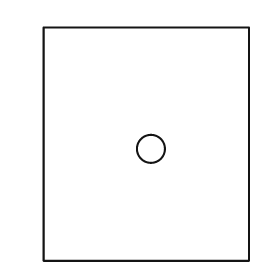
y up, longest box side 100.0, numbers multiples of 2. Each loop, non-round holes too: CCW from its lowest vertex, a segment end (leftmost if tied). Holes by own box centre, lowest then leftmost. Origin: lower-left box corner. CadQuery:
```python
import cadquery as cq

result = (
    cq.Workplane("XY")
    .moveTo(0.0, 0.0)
    .lineTo(88.0, 0.0)
    .lineTo(88.0, 100.0)
    .lineTo(0.0, 100.0)
    .close()
    .moveTo(46.0, 48.0)
    .circle(6.0)
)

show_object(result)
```